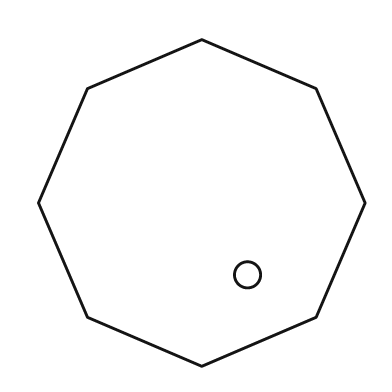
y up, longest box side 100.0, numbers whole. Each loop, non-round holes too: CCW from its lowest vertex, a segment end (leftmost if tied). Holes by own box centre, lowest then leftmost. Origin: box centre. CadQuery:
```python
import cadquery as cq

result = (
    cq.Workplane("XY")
    .moveTo(0.0, -50.0)
    .lineTo(35.0, -35.0)
    .lineTo(50.0, 0.0)
    .lineTo(35.0, 35.0)
    .lineTo(0.0, 50.0)
    .lineTo(-35.0, 35.0)
    .lineTo(-50.0, 0.0)
    .lineTo(-35.0, -35.0)
    .close()
    .moveTo(14.0, -22.0)
    .circle(4.0)
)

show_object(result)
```